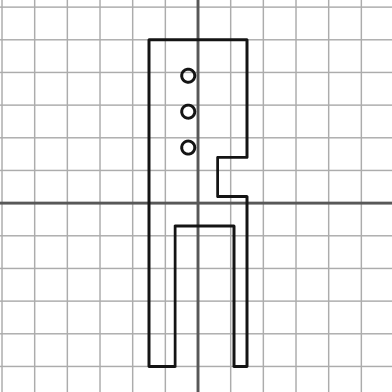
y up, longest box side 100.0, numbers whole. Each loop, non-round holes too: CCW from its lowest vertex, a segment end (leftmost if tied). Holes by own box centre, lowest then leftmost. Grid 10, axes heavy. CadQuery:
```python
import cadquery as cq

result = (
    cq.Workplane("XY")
    .moveTo(-15.0, -50.0)
    .lineTo(-7.0, -50.0)
    .lineTo(-7.0, -7.0)
    .lineTo(11.0, -7.0)
    .lineTo(11.0, -50.0)
    .lineTo(15.0, -50.0)
    .lineTo(15.0, 2.0)
    .lineTo(6.0, 2.0)
    .lineTo(6.0, 14.0)
    .lineTo(15.0, 14.0)
    .lineTo(15.0, 50.0)
    .lineTo(-15.0, 50.0)
    .close()
    .moveTo(-3.0, 17.0)
    .circle(2.0)
    .moveTo(-3.0, 28.0)
    .circle(2.0)
    .moveTo(-3.0, 39.0)
    .circle(2.0)
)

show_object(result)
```